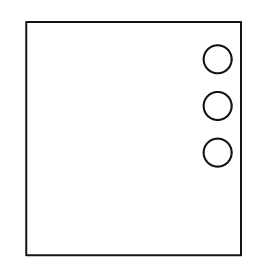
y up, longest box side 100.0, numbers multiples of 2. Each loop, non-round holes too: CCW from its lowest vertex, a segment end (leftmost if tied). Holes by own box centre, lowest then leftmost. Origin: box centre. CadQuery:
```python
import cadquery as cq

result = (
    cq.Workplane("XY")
    .moveTo(-46.0, -50.0)
    .lineTo(46.0, -50.0)
    .lineTo(46.0, 50.0)
    .lineTo(-46.0, 50.0)
    .close()
    .moveTo(36.0, -6.0)
    .circle(6.0)
    .moveTo(36.0, 14.0)
    .circle(6.0)
    .moveTo(36.0, 34.0)
    .circle(6.0)
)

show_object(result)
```